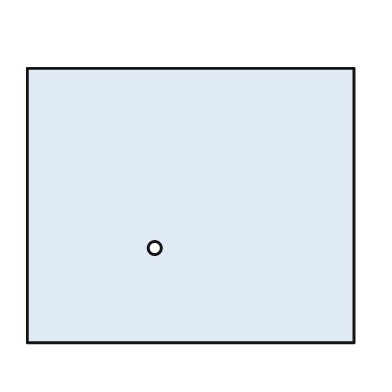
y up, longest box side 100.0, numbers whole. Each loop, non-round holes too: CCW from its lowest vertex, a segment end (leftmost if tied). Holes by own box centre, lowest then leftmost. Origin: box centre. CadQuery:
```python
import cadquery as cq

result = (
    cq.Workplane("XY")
    .moveTo(-50.0, -42.0)
    .lineTo(50.0, -42.0)
    .lineTo(50.0, 42.0)
    .lineTo(-50.0, 42.0)
    .close()
    .moveTo(-11.0, -13.0)
    .circle(2.0)
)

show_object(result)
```